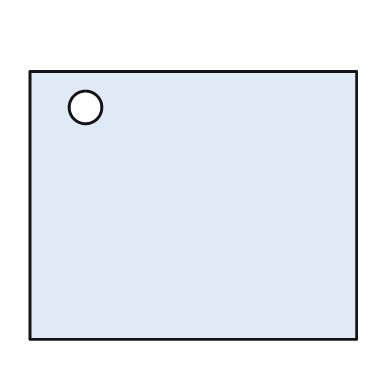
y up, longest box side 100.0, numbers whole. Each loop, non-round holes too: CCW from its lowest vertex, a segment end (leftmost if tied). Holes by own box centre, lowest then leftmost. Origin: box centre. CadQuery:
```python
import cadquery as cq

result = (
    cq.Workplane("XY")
    .moveTo(-50.0, -41.0)
    .lineTo(50.0, -41.0)
    .lineTo(50.0, 41.0)
    .lineTo(-50.0, 41.0)
    .close()
    .moveTo(-33.0, 30.0)
    .circle(5.0)
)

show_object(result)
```